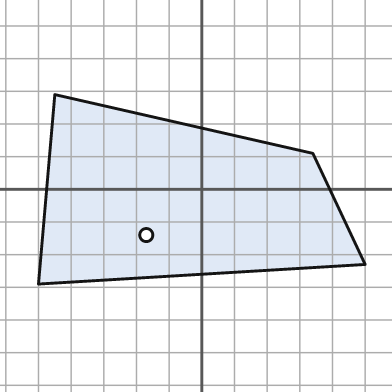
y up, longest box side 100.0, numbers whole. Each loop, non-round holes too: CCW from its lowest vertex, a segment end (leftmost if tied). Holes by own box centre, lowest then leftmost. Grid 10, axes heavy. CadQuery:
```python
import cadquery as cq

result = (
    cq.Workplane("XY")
    .moveTo(-50.0, -29.0)
    .lineTo(50.0, -23.0)
    .lineTo(34.0, 11.0)
    .lineTo(-45.0, 29.0)
    .close()
    .moveTo(-17.0, -14.0)
    .circle(2.0)
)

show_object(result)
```